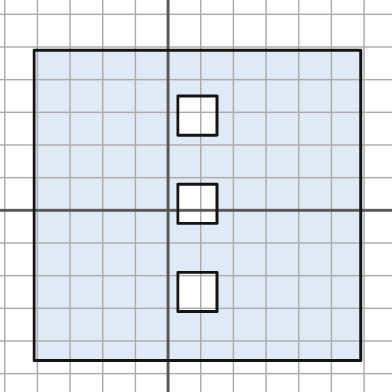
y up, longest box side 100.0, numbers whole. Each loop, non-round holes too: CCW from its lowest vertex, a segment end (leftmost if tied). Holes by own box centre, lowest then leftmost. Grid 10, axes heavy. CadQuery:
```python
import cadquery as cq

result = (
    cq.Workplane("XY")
    .moveTo(-41.0, -46.0)
    .lineTo(59.0, -46.0)
    .lineTo(59.0, 49.0)
    .lineTo(-41.0, 49.0)
    .close()
    .moveTo(3.0, -31.0)
    .lineTo(15.0, -31.0)
    .lineTo(15.0, -19.0)
    .lineTo(3.0, -19.0)
    .close()
    .moveTo(3.0, -4.0)
    .lineTo(15.0, -4.0)
    .lineTo(15.0, 8.0)
    .lineTo(3.0, 8.0)
    .close()
    .moveTo(3.0, 23.0)
    .lineTo(15.0, 23.0)
    .lineTo(15.0, 35.0)
    .lineTo(3.0, 35.0)
    .close()
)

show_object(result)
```